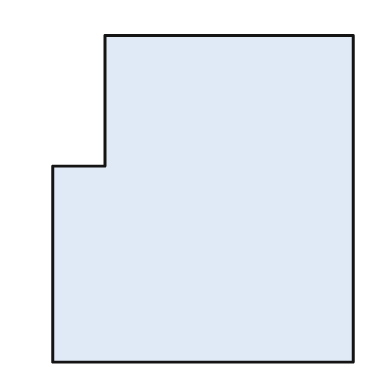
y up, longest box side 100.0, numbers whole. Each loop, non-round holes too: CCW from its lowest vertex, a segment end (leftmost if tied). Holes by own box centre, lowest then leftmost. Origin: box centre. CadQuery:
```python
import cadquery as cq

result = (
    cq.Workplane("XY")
    .moveTo(-46.0, -50.0)
    .lineTo(46.0, -50.0)
    .lineTo(46.0, 50.0)
    .lineTo(-30.0, 50.0)
    .lineTo(-30.0, 10.0)
    .lineTo(-46.0, 10.0)
    .close()
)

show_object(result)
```